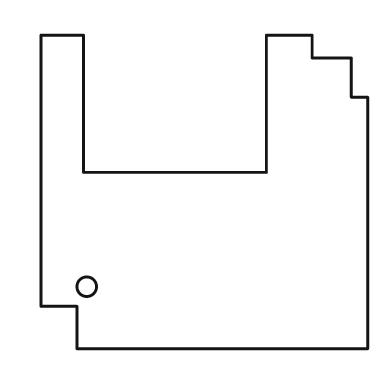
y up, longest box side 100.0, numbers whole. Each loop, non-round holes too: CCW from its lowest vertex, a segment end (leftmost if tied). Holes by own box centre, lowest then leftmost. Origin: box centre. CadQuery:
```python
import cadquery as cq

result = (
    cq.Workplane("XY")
    .moveTo(-39.0, -48.0)
    .lineTo(50.0, -48.0)
    .lineTo(50.0, 29.0)
    .lineTo(45.0, 29.0)
    .lineTo(45.0, 41.0)
    .lineTo(33.0, 41.0)
    .lineTo(33.0, 48.0)
    .lineTo(19.0, 48.0)
    .lineTo(19.0, 6.0)
    .lineTo(-37.0, 6.0)
    .lineTo(-37.0, 48.0)
    .lineTo(-50.0, 48.0)
    .lineTo(-50.0, -35.0)
    .lineTo(-39.0, -35.0)
    .close()
    .moveTo(-36.0, -29.0)
    .circle(3.0)
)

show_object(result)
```